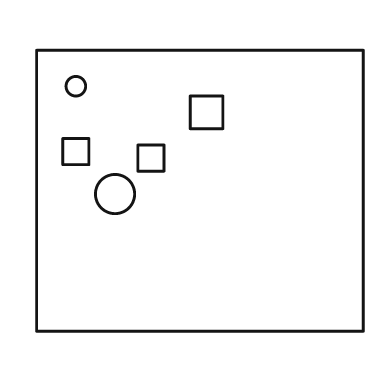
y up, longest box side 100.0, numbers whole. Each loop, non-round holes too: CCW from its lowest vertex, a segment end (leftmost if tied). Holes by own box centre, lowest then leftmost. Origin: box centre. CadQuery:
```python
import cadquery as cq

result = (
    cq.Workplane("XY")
    .moveTo(-50.0, -43.0)
    .lineTo(50.0, -43.0)
    .lineTo(50.0, 43.0)
    .lineTo(-50.0, 43.0)
    .close()
    .moveTo(-26.0, -1.0)
    .circle(6.0)
    .moveTo(-19.0, 6.0)
    .lineTo(-11.0, 6.0)
    .lineTo(-11.0, 14.0)
    .lineTo(-19.0, 14.0)
    .close()
    .moveTo(-42.0, 8.0)
    .lineTo(-34.0, 8.0)
    .lineTo(-34.0, 16.0)
    .lineTo(-42.0, 16.0)
    .close()
    .moveTo(-3.0, 19.0)
    .lineTo(7.0, 19.0)
    .lineTo(7.0, 29.0)
    .lineTo(-3.0, 29.0)
    .close()
    .moveTo(-38.0, 32.0)
    .circle(3.0)
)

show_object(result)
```